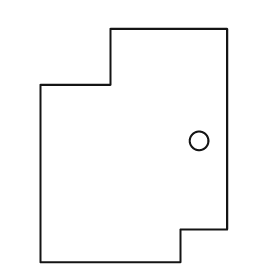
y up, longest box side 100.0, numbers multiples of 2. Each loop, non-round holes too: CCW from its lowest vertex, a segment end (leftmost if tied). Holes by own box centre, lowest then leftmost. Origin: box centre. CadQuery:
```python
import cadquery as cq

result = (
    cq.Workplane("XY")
    .moveTo(-40.0, -50.0)
    .lineTo(20.0, -50.0)
    .lineTo(20.0, -36.0)
    .lineTo(40.0, -36.0)
    .lineTo(40.0, 50.0)
    .lineTo(-10.0, 50.0)
    .lineTo(-10.0, 26.0)
    .lineTo(-40.0, 26.0)
    .close()
    .moveTo(28.0, 2.0)
    .circle(4.0)
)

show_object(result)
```